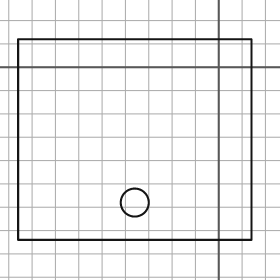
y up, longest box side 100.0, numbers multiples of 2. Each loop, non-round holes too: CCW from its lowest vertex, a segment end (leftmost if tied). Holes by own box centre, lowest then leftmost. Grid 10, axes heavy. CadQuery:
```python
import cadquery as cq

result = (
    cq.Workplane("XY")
    .moveTo(-86.0, -74.0)
    .lineTo(14.0, -74.0)
    .lineTo(14.0, 12.0)
    .lineTo(-86.0, 12.0)
    .close()
    .moveTo(-36.0, -58.0)
    .circle(6.0)
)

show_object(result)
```